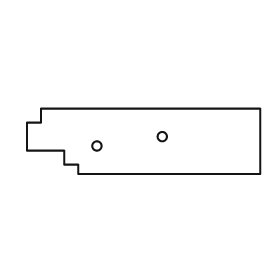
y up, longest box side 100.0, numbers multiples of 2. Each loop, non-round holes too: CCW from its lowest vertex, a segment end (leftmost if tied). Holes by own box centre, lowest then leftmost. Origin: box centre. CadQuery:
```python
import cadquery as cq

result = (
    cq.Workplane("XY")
    .moveTo(-28.0, -14.0)
    .lineTo(50.0, -14.0)
    .lineTo(50.0, 14.0)
    .lineTo(-44.0, 14.0)
    .lineTo(-44.0, 8.0)
    .lineTo(-50.0, 8.0)
    .lineTo(-50.0, -4.0)
    .lineTo(-34.0, -4.0)
    .lineTo(-34.0, -10.0)
    .lineTo(-28.0, -10.0)
    .close()
    .moveTo(-20.0, -2.0)
    .circle(2.0)
    .moveTo(8.0, 2.0)
    .circle(2.0)
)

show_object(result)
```